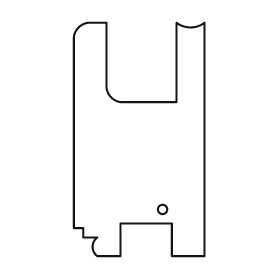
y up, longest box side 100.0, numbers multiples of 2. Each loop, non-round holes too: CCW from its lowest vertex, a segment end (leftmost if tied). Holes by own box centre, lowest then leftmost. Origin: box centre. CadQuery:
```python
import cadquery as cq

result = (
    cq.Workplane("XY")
    .moveTo(-18.0, -50.0)
    .lineTo(-8.0, -50.0)
    .lineTo(-8.0, -36.0)
    .lineTo(14.0, -36.0)
    .lineTo(14.0, -50.0)
    .lineTo(28.0, -50.0)
    .lineTo(28.0, 50.0)
    .threePointArc((22.0, 48.0), (16.0, 50.0))
    .lineTo(16.0, 16.0)
    .lineTo(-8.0, 16.0)
    .threePointArc((-12.0, 18.0), (-14.0, 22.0))
    .lineTo(-14.0, 50.0)
    .lineTo(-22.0, 50.0)
    .threePointArc((-26.0, 48.0), (-28.0, 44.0))
    .lineTo(-28.0, -38.0)
    .lineTo(-24.0, -38.0)
    .lineTo(-24.0, -42.0)
    .lineTo(-18.0, -42.0)
    .threePointArc((-20.0, -46.0), (-18.0, -50.0))
    .close()
    .moveTo(10.0, -30.0)
    .circle(2.0)
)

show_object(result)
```